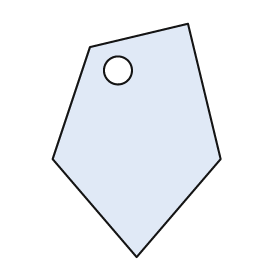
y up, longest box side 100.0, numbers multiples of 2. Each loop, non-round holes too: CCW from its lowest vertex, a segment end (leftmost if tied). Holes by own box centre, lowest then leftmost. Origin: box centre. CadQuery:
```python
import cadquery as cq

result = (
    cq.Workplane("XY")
    .moveTo(0.0, -50.0)
    .lineTo(36.0, -8.0)
    .lineTo(22.0, 50.0)
    .lineTo(-20.0, 40.0)
    .lineTo(-36.0, -8.0)
    .close()
    .moveTo(-8.0, 30.0)
    .circle(6.0)
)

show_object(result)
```